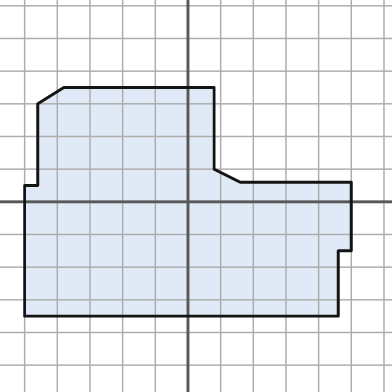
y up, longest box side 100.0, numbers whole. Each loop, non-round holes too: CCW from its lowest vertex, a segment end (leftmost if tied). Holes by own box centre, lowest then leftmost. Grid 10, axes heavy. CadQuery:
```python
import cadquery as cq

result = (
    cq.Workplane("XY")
    .moveTo(-50.0, -35.0)
    .lineTo(46.0, -35.0)
    .lineTo(46.0, -15.0)
    .lineTo(50.0, -15.0)
    .lineTo(50.0, 6.0)
    .lineTo(16.0, 6.0)
    .lineTo(8.0, 10.0)
    .lineTo(8.0, 35.0)
    .lineTo(-38.0, 35.0)
    .lineTo(-46.0, 30.0)
    .lineTo(-46.0, 5.0)
    .lineTo(-50.0, 5.0)
    .close()
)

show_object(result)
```